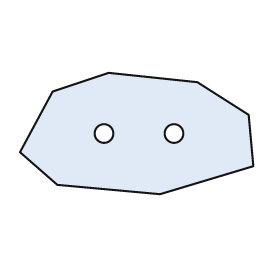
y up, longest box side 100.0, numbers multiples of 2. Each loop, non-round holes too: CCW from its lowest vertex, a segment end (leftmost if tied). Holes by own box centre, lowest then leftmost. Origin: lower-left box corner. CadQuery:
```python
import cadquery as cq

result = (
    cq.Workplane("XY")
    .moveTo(60.0, 0.0)
    .lineTo(100.0, 12.0)
    .lineTo(98.0, 34.0)
    .lineTo(76.0, 48.0)
    .lineTo(38.0, 52.0)
    .lineTo(14.0, 44.0)
    .lineTo(0.0, 18.0)
    .lineTo(16.0, 4.0)
    .close()
    .moveTo(36.0, 26.0)
    .circle(4.0)
    .moveTo(66.0, 26.0)
    .circle(4.0)
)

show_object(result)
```